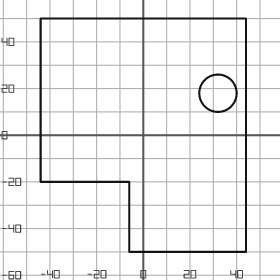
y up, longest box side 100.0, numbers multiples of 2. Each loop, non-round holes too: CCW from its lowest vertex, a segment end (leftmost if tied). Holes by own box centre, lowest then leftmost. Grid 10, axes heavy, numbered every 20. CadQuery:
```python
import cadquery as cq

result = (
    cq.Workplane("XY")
    .moveTo(-6.0, -50.0)
    .lineTo(44.0, -50.0)
    .lineTo(44.0, 50.0)
    .lineTo(-44.0, 50.0)
    .lineTo(-44.0, -20.0)
    .lineTo(-6.0, -20.0)
    .close()
    .moveTo(32.0, 18.0)
    .circle(8.0)
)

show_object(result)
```